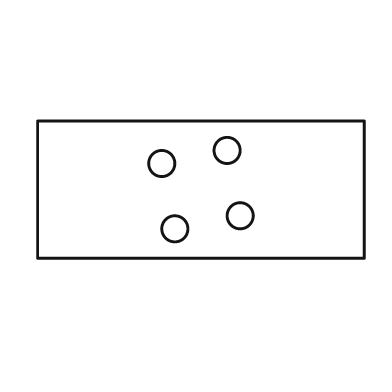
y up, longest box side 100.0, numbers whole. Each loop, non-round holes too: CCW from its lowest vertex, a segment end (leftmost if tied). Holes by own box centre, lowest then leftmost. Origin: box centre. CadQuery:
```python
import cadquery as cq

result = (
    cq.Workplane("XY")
    .moveTo(-50.0, -21.0)
    .lineTo(50.0, -21.0)
    .lineTo(50.0, 21.0)
    .lineTo(-50.0, 21.0)
    .close()
    .moveTo(-8.0, -12.0)
    .circle(4.0)
    .moveTo(12.0, -8.0)
    .circle(4.0)
    .moveTo(-12.0, 8.0)
    .circle(4.0)
    .moveTo(8.0, 12.0)
    .circle(4.0)
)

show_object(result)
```